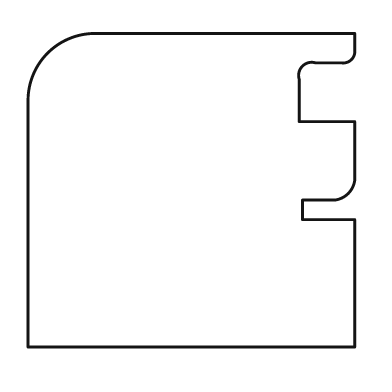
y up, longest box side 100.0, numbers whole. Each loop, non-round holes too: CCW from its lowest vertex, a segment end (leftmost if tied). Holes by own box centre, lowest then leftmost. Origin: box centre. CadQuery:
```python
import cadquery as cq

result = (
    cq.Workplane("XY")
    .moveTo(-50.0, -48.0)
    .lineTo(50.0, -48.0)
    .lineTo(50.0, -9.0)
    .lineTo(34.0, -9.0)
    .lineTo(34.0, -3.0)
    .lineTo(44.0, -3.0)
    .threePointArc((48.0, -1.0), (50.0, 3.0))
    .lineTo(50.0, 21.0)
    .lineTo(33.0, 21.0)
    .lineTo(33.0, 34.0)
    .threePointArc((34.0, 38.0), (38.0, 39.0))
    .lineTo(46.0, 39.0)
    .threePointArc((49.0, 40.0), (50.0, 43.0))
    .lineTo(50.0, 48.0)
    .lineTo(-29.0, 48.0)
    .threePointArc((-44.0, 42.0), (-50.0, 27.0))
    .close()
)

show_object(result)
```